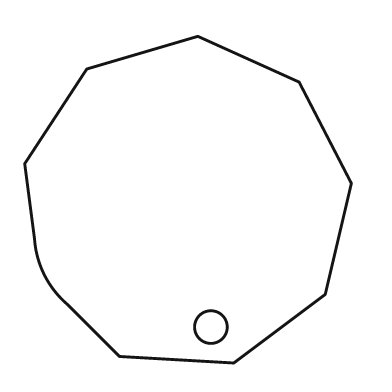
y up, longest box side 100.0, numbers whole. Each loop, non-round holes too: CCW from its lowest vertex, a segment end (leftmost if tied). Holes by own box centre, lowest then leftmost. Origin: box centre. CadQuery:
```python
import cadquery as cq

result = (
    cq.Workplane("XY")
    .moveTo(14.0, -50.0)
    .lineTo(42.0, -29.0)
    .lineTo(50.0, 5.0)
    .lineTo(34.0, 36.0)
    .lineTo(3.0, 50.0)
    .lineTo(-31.0, 40.0)
    .lineTo(-50.0, 11.0)
    .lineTo(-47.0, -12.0)
    .threePointArc((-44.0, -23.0), (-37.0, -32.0))
    .lineTo(-21.0, -48.0)
    .close()
    .moveTo(7.0, -39.0)
    .circle(5.0)
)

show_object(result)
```